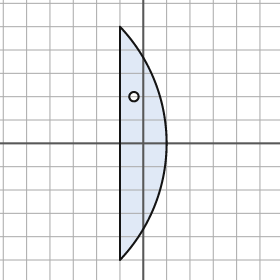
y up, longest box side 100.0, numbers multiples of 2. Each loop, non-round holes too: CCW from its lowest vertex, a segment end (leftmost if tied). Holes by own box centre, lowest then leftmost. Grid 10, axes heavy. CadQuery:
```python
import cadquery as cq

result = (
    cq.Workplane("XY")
    .moveTo(-10.0, -50.0)
    .threePointArc((10.0, 0.0), (-10.0, 50.0))
    .close()
    .moveTo(-4.0, 20.0)
    .circle(2.0)
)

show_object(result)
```